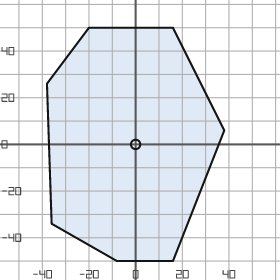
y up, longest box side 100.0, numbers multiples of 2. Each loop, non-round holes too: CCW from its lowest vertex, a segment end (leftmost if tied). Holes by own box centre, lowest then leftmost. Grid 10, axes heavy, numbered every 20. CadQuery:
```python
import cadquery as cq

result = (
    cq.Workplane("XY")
    .moveTo(-8.0, -50.0)
    .lineTo(16.0, -50.0)
    .lineTo(38.0, 6.0)
    .lineTo(16.0, 50.0)
    .lineTo(-20.0, 50.0)
    .lineTo(-38.0, 26.0)
    .lineTo(-36.0, -34.0)
    .close()
    .moveTo(0.0, 0.0)
    .circle(2.0)
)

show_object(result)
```